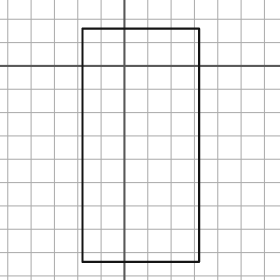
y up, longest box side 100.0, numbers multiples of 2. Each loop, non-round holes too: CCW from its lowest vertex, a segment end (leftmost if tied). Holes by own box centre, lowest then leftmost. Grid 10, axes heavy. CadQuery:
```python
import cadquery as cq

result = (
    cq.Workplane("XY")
    .moveTo(-18.0, -84.0)
    .lineTo(32.0, -84.0)
    .lineTo(32.0, 16.0)
    .lineTo(-18.0, 16.0)
    .close()
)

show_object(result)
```